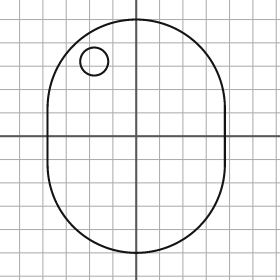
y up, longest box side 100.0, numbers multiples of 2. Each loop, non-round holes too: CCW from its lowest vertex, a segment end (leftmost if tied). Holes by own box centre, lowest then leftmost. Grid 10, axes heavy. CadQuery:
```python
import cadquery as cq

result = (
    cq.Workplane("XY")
    .moveTo(-38.0, -12.0)
    .threePointArc((0.0, -50.0), (38.0, -12.0))
    .lineTo(38.0, 12.0)
    .threePointArc((0.0, 50.0), (-38.0, 12.0))
    .close()
    .moveTo(-18.0, 32.0)
    .circle(6.0)
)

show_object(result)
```